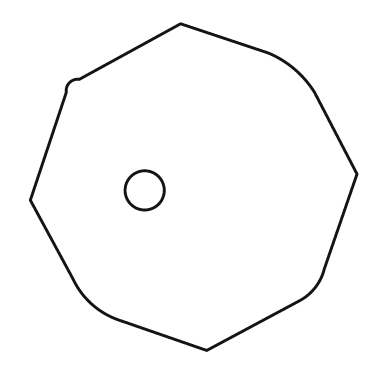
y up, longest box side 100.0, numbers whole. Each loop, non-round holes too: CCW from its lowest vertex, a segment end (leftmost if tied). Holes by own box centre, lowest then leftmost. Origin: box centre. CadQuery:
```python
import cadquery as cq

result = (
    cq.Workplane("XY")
    .moveTo(4.0, -50.0)
    .lineTo(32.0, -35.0)
    .threePointArc((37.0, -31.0), (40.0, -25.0))
    .lineTo(50.0, 4.0)
    .lineTo(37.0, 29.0)
    .threePointArc((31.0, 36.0), (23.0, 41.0))
    .lineTo(-4.0, 50.0)
    .lineTo(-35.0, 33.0)
    .threePointArc((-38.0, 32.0), (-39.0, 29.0))
    .lineTo(-50.0, -4.0)
    .lineTo(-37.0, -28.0)
    .threePointArc((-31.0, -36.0), (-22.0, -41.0))
    .close()
    .moveTo(-15.0, -1.0)
    .circle(6.0)
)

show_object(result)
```